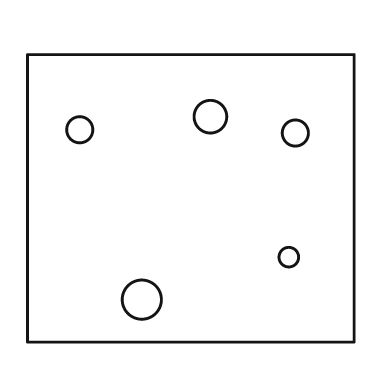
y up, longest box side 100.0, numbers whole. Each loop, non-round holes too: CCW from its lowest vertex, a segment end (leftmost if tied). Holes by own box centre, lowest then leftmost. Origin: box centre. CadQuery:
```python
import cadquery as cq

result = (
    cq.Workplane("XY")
    .moveTo(-50.0, -44.0)
    .lineTo(50.0, -44.0)
    .lineTo(50.0, 44.0)
    .lineTo(-50.0, 44.0)
    .close()
    .moveTo(-15.0, -31.0)
    .circle(6.0)
    .moveTo(30.0, -18.0)
    .circle(3.0)
    .moveTo(32.0, 20.0)
    .circle(4.0)
    .moveTo(-34.0, 21.0)
    .circle(4.0)
    .moveTo(6.0, 25.0)
    .circle(5.0)
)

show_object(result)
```